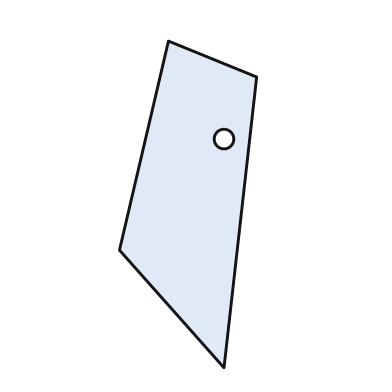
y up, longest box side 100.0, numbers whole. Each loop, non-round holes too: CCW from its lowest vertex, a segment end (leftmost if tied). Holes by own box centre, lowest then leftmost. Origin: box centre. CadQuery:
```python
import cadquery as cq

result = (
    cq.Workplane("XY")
    .moveTo(11.0, -50.0)
    .lineTo(21.0, 39.0)
    .lineTo(-6.0, 50.0)
    .lineTo(-21.0, -14.0)
    .close()
    .moveTo(11.0, 20.0)
    .circle(3.0)
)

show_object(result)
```